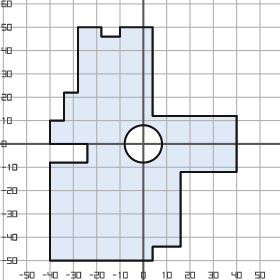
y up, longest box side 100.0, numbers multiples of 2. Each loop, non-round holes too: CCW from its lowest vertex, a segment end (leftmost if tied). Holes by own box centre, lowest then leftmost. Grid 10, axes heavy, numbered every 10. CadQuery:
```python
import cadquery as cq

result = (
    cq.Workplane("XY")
    .moveTo(-40.0, -50.0)
    .lineTo(4.0, -50.0)
    .lineTo(4.0, -44.0)
    .lineTo(16.0, -44.0)
    .lineTo(16.0, -12.0)
    .lineTo(40.0, -12.0)
    .lineTo(40.0, 12.0)
    .lineTo(4.0, 12.0)
    .lineTo(4.0, 50.0)
    .lineTo(-10.0, 50.0)
    .lineTo(-10.0, 46.0)
    .lineTo(-18.0, 46.0)
    .lineTo(-18.0, 50.0)
    .lineTo(-28.0, 50.0)
    .lineTo(-28.0, 22.0)
    .lineTo(-34.0, 22.0)
    .lineTo(-34.0, 10.0)
    .lineTo(-40.0, 10.0)
    .lineTo(-40.0, 0.0)
    .lineTo(-24.0, 0.0)
    .lineTo(-24.0, -8.0)
    .lineTo(-40.0, -8.0)
    .close()
    .moveTo(0.0, 0.0)
    .circle(8.0)
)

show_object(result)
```